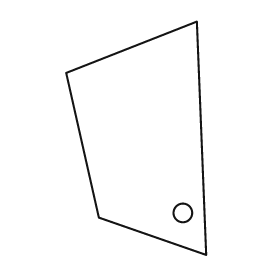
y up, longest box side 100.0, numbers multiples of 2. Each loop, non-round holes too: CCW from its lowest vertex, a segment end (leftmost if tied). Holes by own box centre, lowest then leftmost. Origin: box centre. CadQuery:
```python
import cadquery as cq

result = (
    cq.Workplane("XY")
    .moveTo(30.0, -50.0)
    .lineTo(26.0, 50.0)
    .lineTo(-30.0, 28.0)
    .lineTo(-16.0, -34.0)
    .close()
    .moveTo(20.0, -32.0)
    .circle(4.0)
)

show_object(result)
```